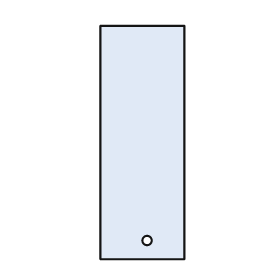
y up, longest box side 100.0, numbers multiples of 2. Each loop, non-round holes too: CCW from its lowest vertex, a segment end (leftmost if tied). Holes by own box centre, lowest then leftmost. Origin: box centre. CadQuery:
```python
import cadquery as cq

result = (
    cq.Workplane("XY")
    .moveTo(-18.0, -50.0)
    .lineTo(18.0, -50.0)
    .lineTo(18.0, 50.0)
    .lineTo(-18.0, 50.0)
    .close()
    .moveTo(2.0, -42.0)
    .circle(2.0)
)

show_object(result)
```